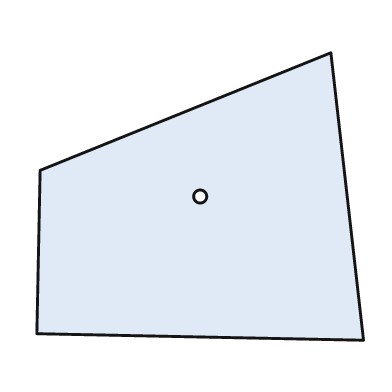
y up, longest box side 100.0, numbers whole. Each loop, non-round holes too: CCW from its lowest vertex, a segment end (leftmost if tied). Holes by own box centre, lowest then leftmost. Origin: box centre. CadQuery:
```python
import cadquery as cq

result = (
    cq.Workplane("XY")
    .moveTo(50.0, -44.0)
    .lineTo(40.0, 44.0)
    .lineTo(-49.0, 8.0)
    .lineTo(-50.0, -42.0)
    .close()
    .moveTo(0.0, 0.0)
    .circle(2.0)
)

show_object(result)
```